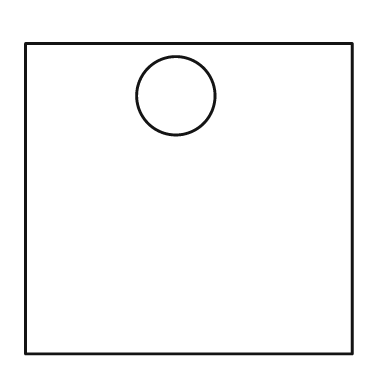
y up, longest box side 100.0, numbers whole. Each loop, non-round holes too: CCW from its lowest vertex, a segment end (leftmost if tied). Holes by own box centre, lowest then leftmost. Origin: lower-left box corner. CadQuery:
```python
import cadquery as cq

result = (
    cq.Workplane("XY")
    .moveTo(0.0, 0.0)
    .lineTo(100.0, 0.0)
    .lineTo(100.0, 95.0)
    .lineTo(0.0, 95.0)
    .close()
    .moveTo(46.0, 79.0)
    .circle(12.0)
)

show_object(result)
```